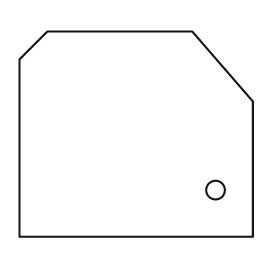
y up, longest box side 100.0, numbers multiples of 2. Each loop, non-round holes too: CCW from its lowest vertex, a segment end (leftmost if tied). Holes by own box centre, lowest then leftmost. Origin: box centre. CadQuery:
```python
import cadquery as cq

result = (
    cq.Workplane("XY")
    .moveTo(-50.0, -44.0)
    .lineTo(50.0, -44.0)
    .lineTo(50.0, 14.0)
    .lineTo(24.0, 44.0)
    .lineTo(-38.0, 44.0)
    .lineTo(-50.0, 32.0)
    .close()
    .moveTo(34.0, -24.0)
    .circle(4.0)
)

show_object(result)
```